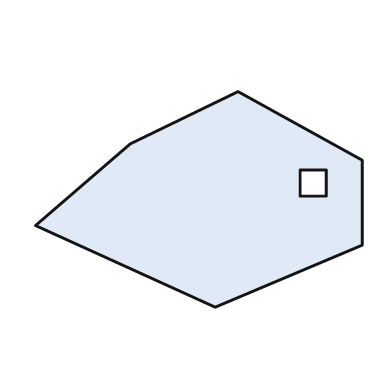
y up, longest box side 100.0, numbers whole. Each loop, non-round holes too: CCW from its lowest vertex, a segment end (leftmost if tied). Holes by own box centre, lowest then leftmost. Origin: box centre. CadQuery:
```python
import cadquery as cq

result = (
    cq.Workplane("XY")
    .moveTo(5.0, -33.0)
    .lineTo(50.0, -14.0)
    .lineTo(50.0, 12.0)
    .lineTo(12.0, 33.0)
    .lineTo(-21.0, 17.0)
    .lineTo(-50.0, -8.0)
    .close()
    .moveTo(31.0, 1.0)
    .lineTo(39.0, 1.0)
    .lineTo(39.0, 9.0)
    .lineTo(31.0, 9.0)
    .close()
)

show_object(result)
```